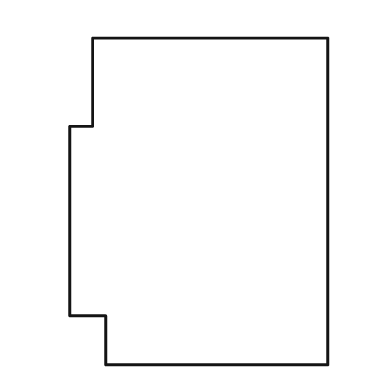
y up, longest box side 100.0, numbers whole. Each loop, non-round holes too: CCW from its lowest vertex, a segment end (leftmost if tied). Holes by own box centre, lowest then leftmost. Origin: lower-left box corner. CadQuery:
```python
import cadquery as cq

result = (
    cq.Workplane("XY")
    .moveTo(11.0, 0.0)
    .lineTo(79.0, 0.0)
    .lineTo(79.0, 100.0)
    .lineTo(7.0, 100.0)
    .lineTo(7.0, 73.0)
    .lineTo(0.0, 73.0)
    .lineTo(0.0, 15.0)
    .lineTo(11.0, 15.0)
    .close()
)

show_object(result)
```